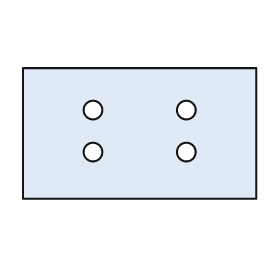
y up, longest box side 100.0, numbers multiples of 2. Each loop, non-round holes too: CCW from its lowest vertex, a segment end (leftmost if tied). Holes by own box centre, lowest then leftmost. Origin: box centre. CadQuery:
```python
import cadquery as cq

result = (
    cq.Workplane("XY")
    .moveTo(-50.0, -28.0)
    .lineTo(50.0, -28.0)
    .lineTo(50.0, 28.0)
    .lineTo(-50.0, 28.0)
    .close()
    .moveTo(-20.0, -8.0)
    .circle(4.0)
    .moveTo(20.0, -8.0)
    .circle(4.0)
    .moveTo(-20.0, 10.0)
    .circle(4.0)
    .moveTo(20.0, 10.0)
    .circle(4.0)
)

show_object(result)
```